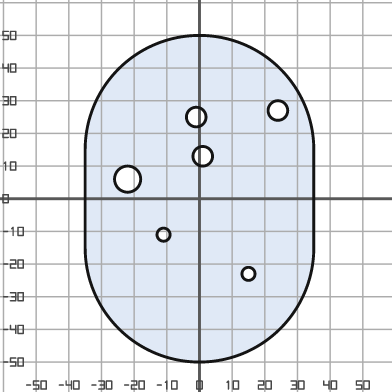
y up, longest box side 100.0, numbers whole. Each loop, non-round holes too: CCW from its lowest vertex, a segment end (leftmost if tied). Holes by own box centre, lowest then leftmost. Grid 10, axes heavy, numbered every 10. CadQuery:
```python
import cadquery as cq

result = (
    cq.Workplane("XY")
    .moveTo(-35.0, -15.0)
    .threePointArc((0.0, -50.0), (35.0, -15.0))
    .lineTo(35.0, 15.0)
    .threePointArc((0.0, 50.0), (-35.0, 15.0))
    .close()
    .moveTo(15.0, -23.0)
    .circle(2.0)
    .moveTo(-11.0, -11.0)
    .circle(2.0)
    .moveTo(-22.0, 6.0)
    .circle(4.0)
    .moveTo(1.0, 13.0)
    .circle(3.0)
    .moveTo(-1.0, 25.0)
    .circle(3.0)
    .moveTo(24.0, 27.0)
    .circle(3.0)
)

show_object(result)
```